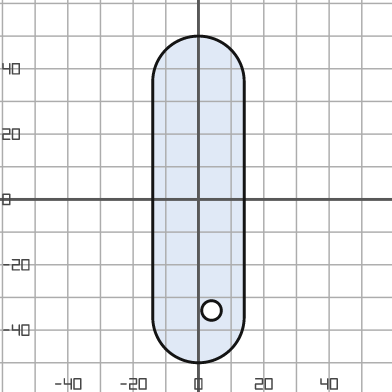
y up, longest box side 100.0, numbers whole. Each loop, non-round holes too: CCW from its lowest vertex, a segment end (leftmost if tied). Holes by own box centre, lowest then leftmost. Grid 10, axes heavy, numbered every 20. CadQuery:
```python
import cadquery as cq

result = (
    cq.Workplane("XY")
    .moveTo(-14.0, -36.0)
    .threePointArc((0.0, -50.0), (14.0, -36.0))
    .lineTo(14.0, 36.0)
    .threePointArc((0.0, 50.0), (-14.0, 36.0))
    .close()
    .moveTo(4.0, -34.0)
    .circle(3.0)
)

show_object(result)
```